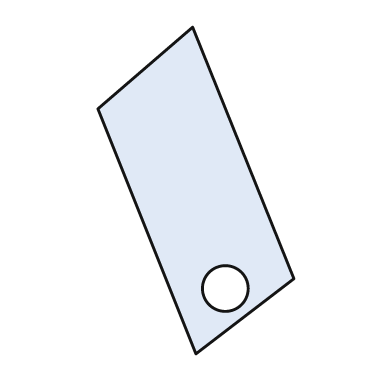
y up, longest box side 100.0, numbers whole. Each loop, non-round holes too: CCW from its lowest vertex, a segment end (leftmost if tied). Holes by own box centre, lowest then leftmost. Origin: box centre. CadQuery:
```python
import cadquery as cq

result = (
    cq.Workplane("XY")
    .moveTo(0.0, -50.0)
    .lineTo(30.0, -27.0)
    .lineTo(-1.0, 50.0)
    .lineTo(-30.0, 25.0)
    .close()
    .moveTo(9.0, -30.0)
    .circle(7.0)
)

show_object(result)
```